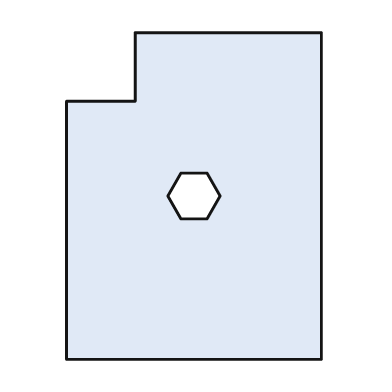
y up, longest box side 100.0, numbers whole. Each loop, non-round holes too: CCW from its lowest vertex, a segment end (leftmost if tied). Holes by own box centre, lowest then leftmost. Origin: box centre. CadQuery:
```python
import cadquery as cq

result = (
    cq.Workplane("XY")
    .moveTo(-39.0, -50.0)
    .lineTo(39.0, -50.0)
    .lineTo(39.0, 50.0)
    .lineTo(-18.0, 50.0)
    .lineTo(-18.0, 29.0)
    .lineTo(-39.0, 29.0)
    .close()
    .moveTo(-4.0, -7.0)
    .lineTo(4.0, -7.0)
    .lineTo(8.0, 0.0)
    .lineTo(4.0, 7.0)
    .lineTo(-4.0, 7.0)
    .lineTo(-8.0, 0.0)
    .close()
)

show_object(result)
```